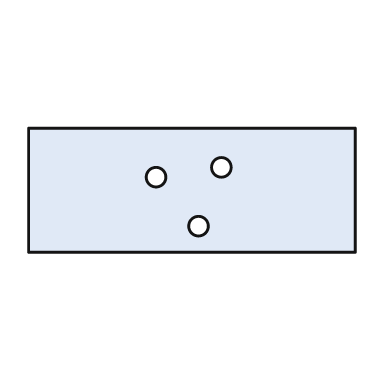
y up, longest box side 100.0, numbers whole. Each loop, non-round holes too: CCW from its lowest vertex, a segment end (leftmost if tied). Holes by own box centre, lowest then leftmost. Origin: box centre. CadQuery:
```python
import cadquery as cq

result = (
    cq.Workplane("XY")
    .moveTo(-50.0, -19.0)
    .lineTo(50.0, -19.0)
    .lineTo(50.0, 19.0)
    .lineTo(-50.0, 19.0)
    .close()
    .moveTo(2.0, -11.0)
    .circle(3.0)
    .moveTo(-11.0, 4.0)
    .circle(3.0)
    .moveTo(9.0, 7.0)
    .circle(3.0)
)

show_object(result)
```